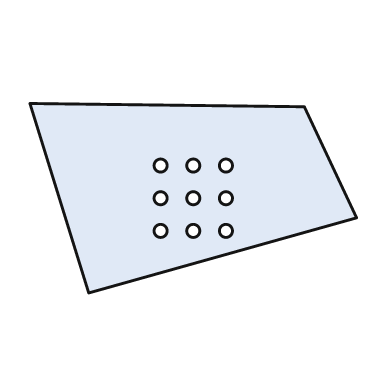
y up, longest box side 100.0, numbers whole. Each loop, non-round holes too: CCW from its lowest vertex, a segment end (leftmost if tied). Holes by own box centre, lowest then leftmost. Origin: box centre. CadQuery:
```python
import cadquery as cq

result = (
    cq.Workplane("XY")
    .moveTo(-32.0, -29.0)
    .lineTo(50.0, -6.0)
    .lineTo(34.0, 28.0)
    .lineTo(-50.0, 29.0)
    .close()
    .moveTo(-10.0, -10.0)
    .circle(2.0)
    .moveTo(0.0, -10.0)
    .circle(2.0)
    .moveTo(10.0, -10.0)
    .circle(2.0)
    .moveTo(-10.0, 0.0)
    .circle(2.0)
    .moveTo(0.0, 0.0)
    .circle(2.0)
    .moveTo(10.0, 0.0)
    .circle(2.0)
    .moveTo(-10.0, 10.0)
    .circle(2.0)
    .moveTo(0.0, 10.0)
    .circle(2.0)
    .moveTo(10.0, 10.0)
    .circle(2.0)
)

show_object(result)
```